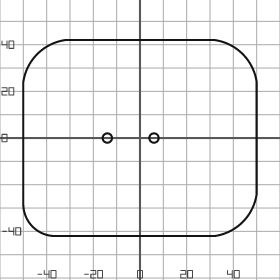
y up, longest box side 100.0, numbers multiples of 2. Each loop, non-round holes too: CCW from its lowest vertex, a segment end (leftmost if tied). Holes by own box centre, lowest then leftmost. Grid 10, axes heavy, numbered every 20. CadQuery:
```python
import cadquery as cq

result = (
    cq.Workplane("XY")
    .moveTo(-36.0, -42.0)
    .lineTo(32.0, -42.0)
    .threePointArc((44.0, -36.0), (50.0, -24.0))
    .lineTo(50.0, 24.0)
    .threePointArc((44.0, 36.0), (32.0, 42.0))
    .lineTo(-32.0, 42.0)
    .threePointArc((-44.0, 36.0), (-50.0, 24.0))
    .lineTo(-50.0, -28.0)
    .threePointArc((-46.0, -38.0), (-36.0, -42.0))
    .close()
    .moveTo(-14.0, 0.0)
    .circle(2.0)
    .moveTo(6.0, 0.0)
    .circle(2.0)
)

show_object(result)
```